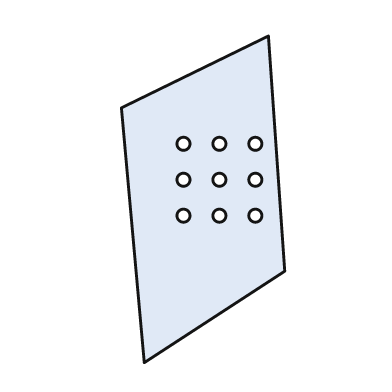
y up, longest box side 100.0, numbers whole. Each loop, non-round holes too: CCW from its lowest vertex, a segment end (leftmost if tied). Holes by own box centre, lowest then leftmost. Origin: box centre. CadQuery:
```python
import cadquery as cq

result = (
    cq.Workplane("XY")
    .moveTo(-18.0, -50.0)
    .lineTo(25.0, -22.0)
    .lineTo(20.0, 50.0)
    .lineTo(-25.0, 28.0)
    .close()
    .moveTo(-6.0, -5.0)
    .circle(2.0)
    .moveTo(5.0, -5.0)
    .circle(2.0)
    .moveTo(16.0, -5.0)
    .circle(2.0)
    .moveTo(-6.0, 6.0)
    .circle(2.0)
    .moveTo(5.0, 6.0)
    .circle(2.0)
    .moveTo(16.0, 6.0)
    .circle(2.0)
    .moveTo(-6.0, 17.0)
    .circle(2.0)
    .moveTo(5.0, 17.0)
    .circle(2.0)
    .moveTo(16.0, 17.0)
    .circle(2.0)
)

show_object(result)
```